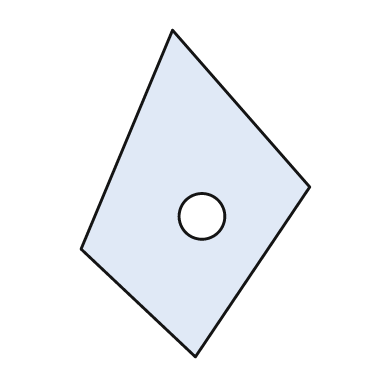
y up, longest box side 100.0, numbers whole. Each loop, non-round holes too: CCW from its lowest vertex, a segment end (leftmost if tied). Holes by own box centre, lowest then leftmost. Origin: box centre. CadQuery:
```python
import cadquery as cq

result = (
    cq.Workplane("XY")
    .moveTo(0.0, -50.0)
    .lineTo(35.0, 2.0)
    .lineTo(-7.0, 50.0)
    .lineTo(-35.0, -17.0)
    .close()
    .moveTo(2.0, -7.0)
    .circle(7.0)
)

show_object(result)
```